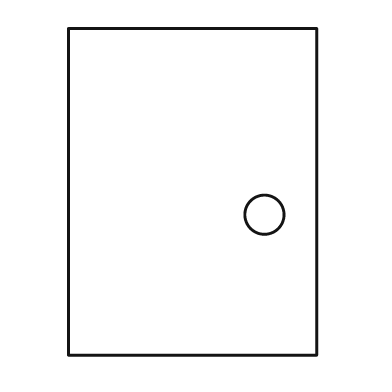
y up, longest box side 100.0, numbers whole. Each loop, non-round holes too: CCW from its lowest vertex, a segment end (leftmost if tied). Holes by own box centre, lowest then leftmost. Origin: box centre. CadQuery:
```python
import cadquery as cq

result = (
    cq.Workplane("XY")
    .moveTo(-38.0, -50.0)
    .lineTo(38.0, -50.0)
    .lineTo(38.0, 50.0)
    .lineTo(-38.0, 50.0)
    .close()
    .moveTo(22.0, -7.0)
    .circle(6.0)
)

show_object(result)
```